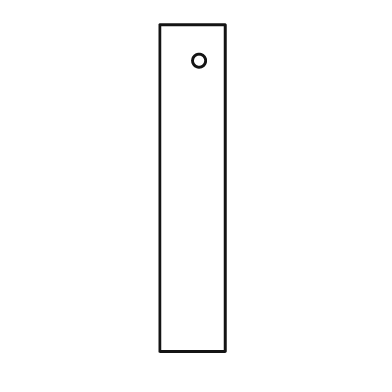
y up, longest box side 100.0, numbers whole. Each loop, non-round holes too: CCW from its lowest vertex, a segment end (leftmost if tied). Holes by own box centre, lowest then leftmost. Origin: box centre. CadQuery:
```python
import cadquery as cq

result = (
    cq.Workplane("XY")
    .moveTo(-10.0, -50.0)
    .lineTo(10.0, -50.0)
    .lineTo(10.0, 50.0)
    .lineTo(-10.0, 50.0)
    .close()
    .moveTo(2.0, 39.0)
    .circle(2.0)
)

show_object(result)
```